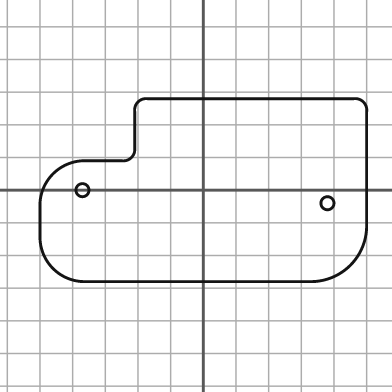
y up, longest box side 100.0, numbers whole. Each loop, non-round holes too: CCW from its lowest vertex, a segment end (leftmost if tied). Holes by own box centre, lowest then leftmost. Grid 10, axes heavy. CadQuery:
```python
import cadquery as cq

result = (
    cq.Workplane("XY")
    .moveTo(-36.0, -28.0)
    .lineTo(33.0, -28.0)
    .threePointArc((45.0, -23.0), (50.0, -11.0))
    .lineTo(50.0, 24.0)
    .threePointArc((49.0, 27.0), (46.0, 28.0))
    .lineTo(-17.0, 28.0)
    .threePointArc((-20.0, 27.0), (-21.0, 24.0))
    .lineTo(-21.0, 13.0)
    .threePointArc((-22.0, 10.0), (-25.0, 9.0))
    .lineTo(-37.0, 9.0)
    .threePointArc((-46.0, 5.0), (-50.0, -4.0))
    .lineTo(-50.0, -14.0)
    .threePointArc((-46.0, -24.0), (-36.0, -28.0))
    .close()
    .moveTo(38.0, -4.0)
    .circle(2.0)
    .moveTo(-37.0, 0.0)
    .circle(2.0)
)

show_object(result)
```